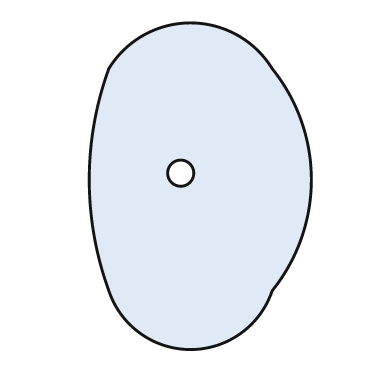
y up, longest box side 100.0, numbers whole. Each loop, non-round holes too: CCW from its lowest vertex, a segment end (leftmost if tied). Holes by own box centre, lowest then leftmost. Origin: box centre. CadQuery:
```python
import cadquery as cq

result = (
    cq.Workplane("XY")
    .moveTo(-28.0, -32.0)
    .threePointArc((-3.0, -50.0), (22.0, -32.0))
    .threePointArc((34.0, 2.0), (22.0, 36.0))
    .threePointArc((-3.0, 50.0), (-28.0, 36.0))
    .threePointArc((-34.0, 2.0), (-28.0, -32.0))
    .close()
    .moveTo(-6.0, 4.0)
    .circle(4.0)
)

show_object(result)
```